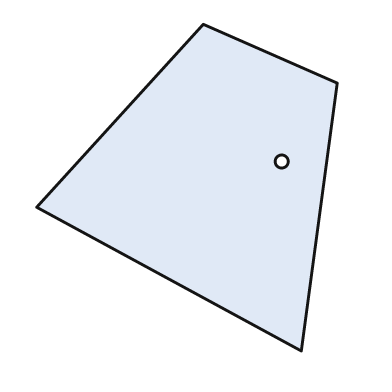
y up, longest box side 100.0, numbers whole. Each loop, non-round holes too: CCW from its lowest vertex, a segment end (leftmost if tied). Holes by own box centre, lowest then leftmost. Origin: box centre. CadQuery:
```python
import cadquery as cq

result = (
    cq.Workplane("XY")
    .moveTo(35.0, -50.0)
    .lineTo(46.0, 32.0)
    .lineTo(5.0, 50.0)
    .lineTo(-46.0, -6.0)
    .close()
    .moveTo(29.0, 8.0)
    .circle(2.0)
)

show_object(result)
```